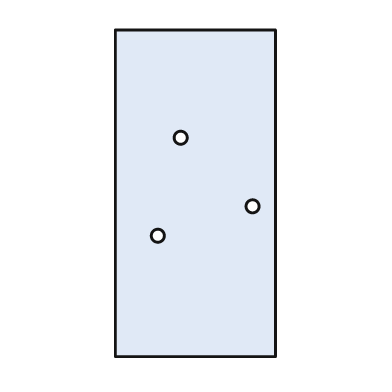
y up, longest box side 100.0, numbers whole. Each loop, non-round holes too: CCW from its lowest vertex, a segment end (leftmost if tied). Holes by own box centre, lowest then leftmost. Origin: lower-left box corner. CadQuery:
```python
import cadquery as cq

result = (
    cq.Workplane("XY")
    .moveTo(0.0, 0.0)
    .lineTo(49.0, 0.0)
    .lineTo(49.0, 100.0)
    .lineTo(0.0, 100.0)
    .close()
    .moveTo(13.0, 37.0)
    .circle(2.0)
    .moveTo(42.0, 46.0)
    .circle(2.0)
    .moveTo(20.0, 67.0)
    .circle(2.0)
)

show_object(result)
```